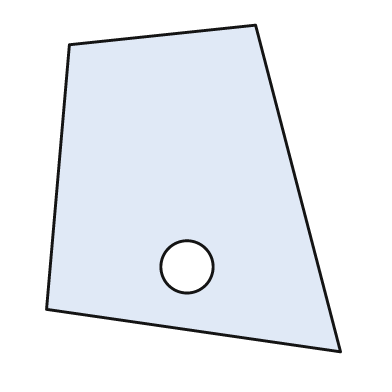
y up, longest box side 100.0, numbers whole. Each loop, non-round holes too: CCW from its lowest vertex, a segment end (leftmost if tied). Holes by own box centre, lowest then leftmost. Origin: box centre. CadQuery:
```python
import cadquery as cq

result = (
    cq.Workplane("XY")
    .moveTo(45.0, -50.0)
    .lineTo(19.0, 50.0)
    .lineTo(-38.0, 44.0)
    .lineTo(-45.0, -37.0)
    .close()
    .moveTo(-2.0, -24.0)
    .circle(8.0)
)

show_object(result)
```